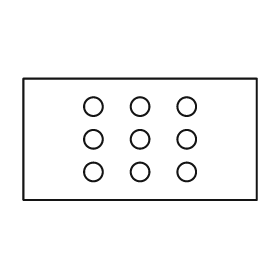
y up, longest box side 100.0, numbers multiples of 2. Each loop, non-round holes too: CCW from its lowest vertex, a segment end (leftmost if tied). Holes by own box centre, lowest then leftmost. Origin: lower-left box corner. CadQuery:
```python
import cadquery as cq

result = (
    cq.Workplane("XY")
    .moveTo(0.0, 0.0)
    .lineTo(100.0, 0.0)
    .lineTo(100.0, 52.0)
    .lineTo(0.0, 52.0)
    .close()
    .moveTo(30.0, 12.0)
    .circle(4.0)
    .moveTo(50.0, 12.0)
    .circle(4.0)
    .moveTo(70.0, 12.0)
    .circle(4.0)
    .moveTo(30.0, 26.0)
    .circle(4.0)
    .moveTo(50.0, 26.0)
    .circle(4.0)
    .moveTo(70.0, 26.0)
    .circle(4.0)
    .moveTo(30.0, 40.0)
    .circle(4.0)
    .moveTo(50.0, 40.0)
    .circle(4.0)
    .moveTo(70.0, 40.0)
    .circle(4.0)
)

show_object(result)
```